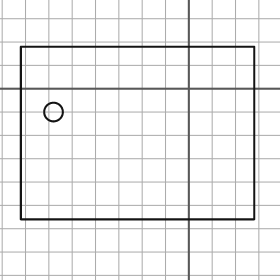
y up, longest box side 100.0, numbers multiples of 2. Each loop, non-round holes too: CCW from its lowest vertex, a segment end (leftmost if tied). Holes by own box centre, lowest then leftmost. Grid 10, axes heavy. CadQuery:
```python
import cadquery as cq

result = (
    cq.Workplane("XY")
    .moveTo(-72.0, -56.0)
    .lineTo(28.0, -56.0)
    .lineTo(28.0, 18.0)
    .lineTo(-72.0, 18.0)
    .close()
    .moveTo(-58.0, -10.0)
    .circle(4.0)
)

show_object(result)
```